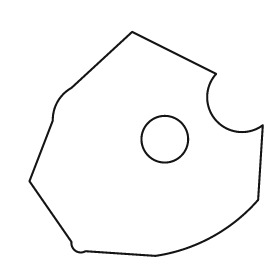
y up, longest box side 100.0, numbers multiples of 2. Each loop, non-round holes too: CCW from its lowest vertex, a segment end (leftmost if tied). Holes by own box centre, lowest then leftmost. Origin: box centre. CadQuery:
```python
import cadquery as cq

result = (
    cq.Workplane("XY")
    .moveTo(4.0, -48.0)
    .threePointArc((28.0, -40.0), (48.0, -24.0))
    .lineTo(50.0, 8.0)
    .threePointArc((30.0, 10.0), (30.0, 30.0))
    .lineTo(-6.0, 48.0)
    .lineTo(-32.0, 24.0)
    .threePointArc((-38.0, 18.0), (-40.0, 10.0))
    .lineTo(-50.0, -16.0)
    .lineTo(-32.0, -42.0)
    .threePointArc((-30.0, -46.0), (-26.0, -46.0))
    .close()
    .moveTo(8.0, 2.0)
    .circle(10.0)
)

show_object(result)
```